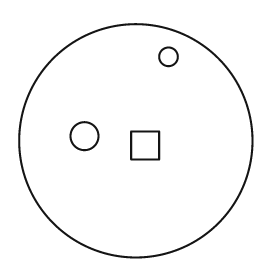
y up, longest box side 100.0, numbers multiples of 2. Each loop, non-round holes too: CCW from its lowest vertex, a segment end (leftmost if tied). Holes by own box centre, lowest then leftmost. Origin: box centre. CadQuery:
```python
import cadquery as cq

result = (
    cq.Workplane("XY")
    .moveTo(0.0, 0.0)
    .circle(50.0)
    .moveTo(-2.0, -8.0)
    .lineTo(10.0, -8.0)
    .lineTo(10.0, 4.0)
    .lineTo(-2.0, 4.0)
    .close()
    .moveTo(-22.0, 2.0)
    .circle(6.0)
    .moveTo(14.0, 36.0)
    .circle(4.0)
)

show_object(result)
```